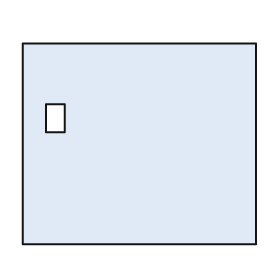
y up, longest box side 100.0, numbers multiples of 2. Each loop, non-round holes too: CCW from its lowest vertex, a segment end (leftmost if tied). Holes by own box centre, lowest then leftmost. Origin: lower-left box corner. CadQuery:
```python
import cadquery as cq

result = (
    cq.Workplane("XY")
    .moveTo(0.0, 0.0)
    .lineTo(100.0, 0.0)
    .lineTo(100.0, 86.0)
    .lineTo(0.0, 86.0)
    .close()
    .moveTo(10.0, 48.0)
    .lineTo(18.0, 48.0)
    .lineTo(18.0, 60.0)
    .lineTo(10.0, 60.0)
    .close()
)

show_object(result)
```